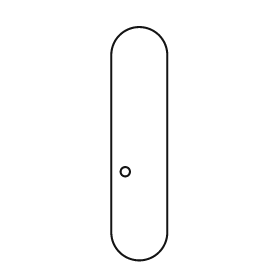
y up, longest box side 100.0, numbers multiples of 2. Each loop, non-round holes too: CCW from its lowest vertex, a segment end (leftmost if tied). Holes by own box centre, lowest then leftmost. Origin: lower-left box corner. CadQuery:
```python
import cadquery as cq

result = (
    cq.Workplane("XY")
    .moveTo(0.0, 12.0)
    .threePointArc((12.0, 0.0), (24.0, 12.0))
    .lineTo(24.0, 88.0)
    .threePointArc((12.0, 100.0), (0.0, 88.0))
    .close()
    .moveTo(6.0, 38.0)
    .circle(2.0)
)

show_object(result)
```